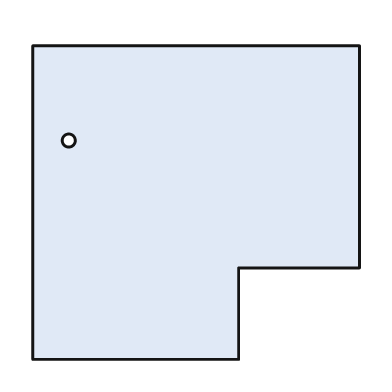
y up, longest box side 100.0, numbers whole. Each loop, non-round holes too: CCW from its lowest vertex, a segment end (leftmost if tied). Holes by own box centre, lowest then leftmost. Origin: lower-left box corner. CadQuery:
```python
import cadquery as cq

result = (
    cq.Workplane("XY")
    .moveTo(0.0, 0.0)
    .lineTo(63.0, 0.0)
    .lineTo(63.0, 28.0)
    .lineTo(100.0, 28.0)
    .lineTo(100.0, 96.0)
    .lineTo(0.0, 96.0)
    .close()
    .moveTo(11.0, 67.0)
    .circle(2.0)
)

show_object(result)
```